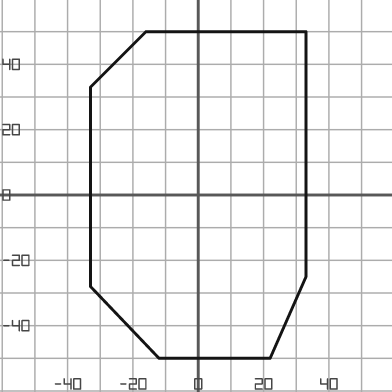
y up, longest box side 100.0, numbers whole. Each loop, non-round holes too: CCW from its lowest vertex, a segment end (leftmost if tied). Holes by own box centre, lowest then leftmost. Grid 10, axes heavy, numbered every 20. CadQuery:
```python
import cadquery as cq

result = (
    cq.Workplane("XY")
    .moveTo(-12.0, -50.0)
    .lineTo(22.0, -50.0)
    .lineTo(33.0, -25.0)
    .lineTo(33.0, 50.0)
    .lineTo(-16.0, 50.0)
    .lineTo(-33.0, 33.0)
    .lineTo(-33.0, -28.0)
    .close()
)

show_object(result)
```